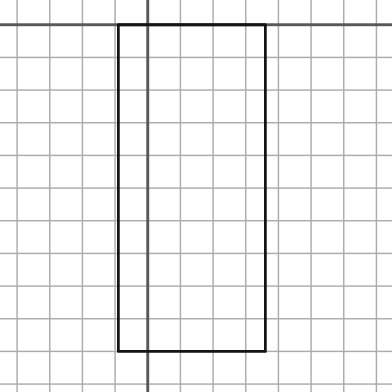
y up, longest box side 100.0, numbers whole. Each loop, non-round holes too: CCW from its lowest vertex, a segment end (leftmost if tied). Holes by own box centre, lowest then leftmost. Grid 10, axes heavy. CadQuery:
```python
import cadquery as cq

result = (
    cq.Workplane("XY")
    .moveTo(-9.0, -100.0)
    .lineTo(36.0, -100.0)
    .lineTo(36.0, 0.0)
    .lineTo(-9.0, 0.0)
    .close()
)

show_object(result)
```